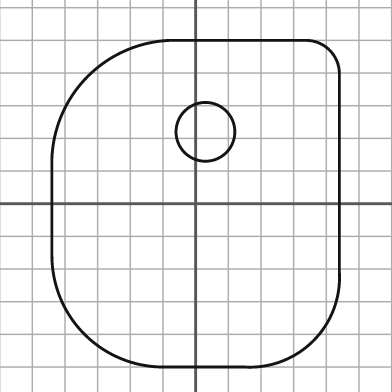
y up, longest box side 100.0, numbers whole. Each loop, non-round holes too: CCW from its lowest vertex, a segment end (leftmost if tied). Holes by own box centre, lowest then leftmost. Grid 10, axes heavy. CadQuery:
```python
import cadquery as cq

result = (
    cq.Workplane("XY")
    .moveTo(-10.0, -50.0)
    .lineTo(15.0, -50.0)
    .threePointArc((36.0, -42.0), (44.0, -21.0))
    .lineTo(44.0, 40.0)
    .threePointArc((41.0, 47.0), (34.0, 50.0))
    .lineTo(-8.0, 50.0)
    .threePointArc((-33.0, 39.0), (-44.0, 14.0))
    .lineTo(-44.0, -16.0)
    .threePointArc((-34.0, -40.0), (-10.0, -50.0))
    .close()
    .moveTo(3.0, 22.0)
    .circle(9.0)
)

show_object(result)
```